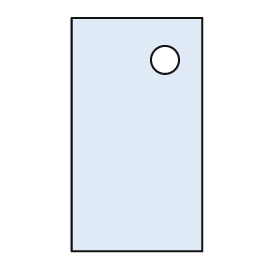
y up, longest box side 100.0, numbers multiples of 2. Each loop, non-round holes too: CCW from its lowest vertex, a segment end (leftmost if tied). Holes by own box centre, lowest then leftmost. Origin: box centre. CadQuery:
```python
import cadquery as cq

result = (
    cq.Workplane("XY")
    .moveTo(-28.0, -50.0)
    .lineTo(28.0, -50.0)
    .lineTo(28.0, 50.0)
    .lineTo(-28.0, 50.0)
    .close()
    .moveTo(12.0, 32.0)
    .circle(6.0)
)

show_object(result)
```